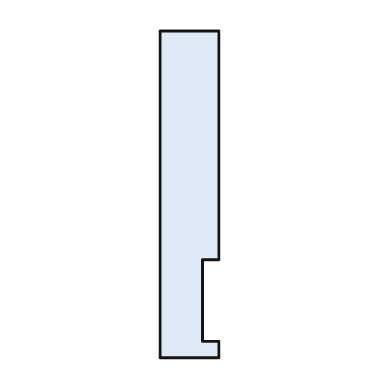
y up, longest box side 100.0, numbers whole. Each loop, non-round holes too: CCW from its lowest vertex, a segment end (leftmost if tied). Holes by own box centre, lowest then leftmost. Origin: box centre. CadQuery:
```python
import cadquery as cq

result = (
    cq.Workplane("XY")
    .moveTo(-9.0, -50.0)
    .lineTo(9.0, -50.0)
    .lineTo(9.0, -45.0)
    .lineTo(4.0, -45.0)
    .lineTo(4.0, -20.0)
    .lineTo(9.0, -20.0)
    .lineTo(9.0, 50.0)
    .lineTo(-9.0, 50.0)
    .close()
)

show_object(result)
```